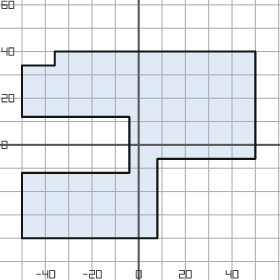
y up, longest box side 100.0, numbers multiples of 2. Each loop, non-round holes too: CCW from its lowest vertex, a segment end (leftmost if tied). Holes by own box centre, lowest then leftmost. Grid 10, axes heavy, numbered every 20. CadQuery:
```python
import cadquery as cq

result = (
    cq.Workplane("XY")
    .moveTo(-50.0, -40.0)
    .lineTo(8.0, -40.0)
    .lineTo(8.0, -6.0)
    .lineTo(50.0, -6.0)
    .lineTo(50.0, 40.0)
    .lineTo(-36.0, 40.0)
    .lineTo(-36.0, 34.0)
    .lineTo(-50.0, 34.0)
    .lineTo(-50.0, 12.0)
    .lineTo(-4.0, 12.0)
    .lineTo(-4.0, -12.0)
    .lineTo(-50.0, -12.0)
    .close()
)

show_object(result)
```